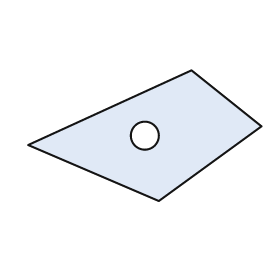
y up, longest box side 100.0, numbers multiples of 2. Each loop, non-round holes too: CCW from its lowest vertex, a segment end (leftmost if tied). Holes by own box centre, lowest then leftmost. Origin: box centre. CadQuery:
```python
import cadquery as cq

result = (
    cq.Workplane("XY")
    .moveTo(6.0, -28.0)
    .lineTo(50.0, 4.0)
    .lineTo(20.0, 28.0)
    .lineTo(-50.0, -4.0)
    .close()
    .moveTo(0.0, 0.0)
    .circle(6.0)
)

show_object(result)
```